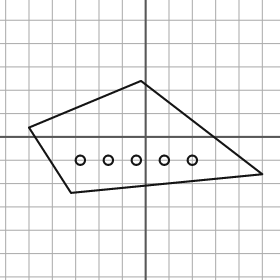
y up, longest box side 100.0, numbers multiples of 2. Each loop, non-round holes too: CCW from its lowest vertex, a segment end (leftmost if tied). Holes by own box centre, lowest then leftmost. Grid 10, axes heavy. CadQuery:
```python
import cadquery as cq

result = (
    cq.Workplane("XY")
    .moveTo(-32.0, -24.0)
    .lineTo(50.0, -16.0)
    .lineTo(-2.0, 24.0)
    .lineTo(-50.0, 4.0)
    .close()
    .moveTo(-28.0, -10.0)
    .circle(2.0)
    .moveTo(-16.0, -10.0)
    .circle(2.0)
    .moveTo(-4.0, -10.0)
    .circle(2.0)
    .moveTo(8.0, -10.0)
    .circle(2.0)
    .moveTo(20.0, -10.0)
    .circle(2.0)
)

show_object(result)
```